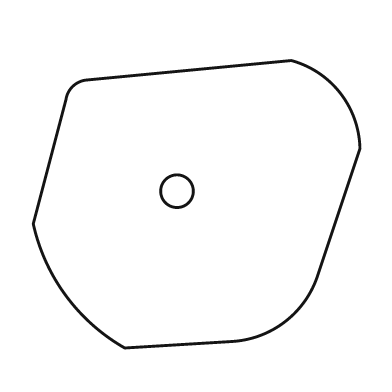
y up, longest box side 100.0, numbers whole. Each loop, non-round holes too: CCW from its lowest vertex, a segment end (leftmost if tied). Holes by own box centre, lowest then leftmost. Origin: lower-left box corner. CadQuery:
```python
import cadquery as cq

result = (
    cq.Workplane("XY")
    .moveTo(28.0, 0.0)
    .lineTo(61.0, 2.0)
    .threePointArc((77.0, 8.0), (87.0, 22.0))
    .lineTo(100.0, 61.0)
    .threePointArc((94.0, 78.0), (79.0, 88.0))
    .lineTo(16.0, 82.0)
    .threePointArc((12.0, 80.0), (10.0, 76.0))
    .lineTo(0.0, 38.0)
    .threePointArc((10.0, 16.0), (28.0, 0.0))
    .close()
    .moveTo(44.0, 48.0)
    .circle(5.0)
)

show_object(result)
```